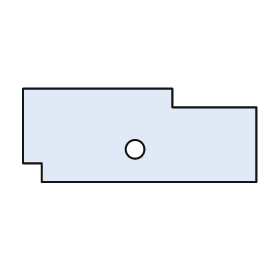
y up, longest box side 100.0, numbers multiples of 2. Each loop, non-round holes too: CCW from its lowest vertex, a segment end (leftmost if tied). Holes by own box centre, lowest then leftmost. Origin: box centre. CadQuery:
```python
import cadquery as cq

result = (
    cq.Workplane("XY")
    .moveTo(-42.0, -20.0)
    .lineTo(50.0, -20.0)
    .lineTo(50.0, 12.0)
    .lineTo(14.0, 12.0)
    .lineTo(14.0, 20.0)
    .lineTo(-50.0, 20.0)
    .lineTo(-50.0, -12.0)
    .lineTo(-42.0, -12.0)
    .close()
    .moveTo(-2.0, -6.0)
    .circle(4.0)
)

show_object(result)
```